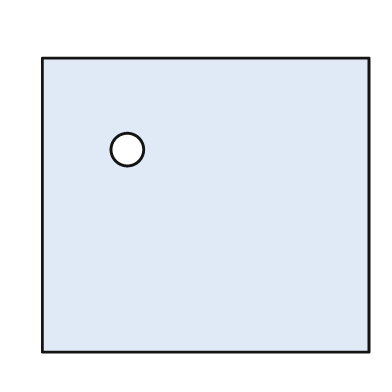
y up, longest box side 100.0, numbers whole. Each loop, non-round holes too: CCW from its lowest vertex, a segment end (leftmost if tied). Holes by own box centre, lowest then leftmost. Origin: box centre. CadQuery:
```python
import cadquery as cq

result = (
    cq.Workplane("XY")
    .moveTo(-50.0, -45.0)
    .lineTo(50.0, -45.0)
    .lineTo(50.0, 45.0)
    .lineTo(-50.0, 45.0)
    .close()
    .moveTo(-24.0, 17.0)
    .circle(5.0)
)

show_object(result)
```